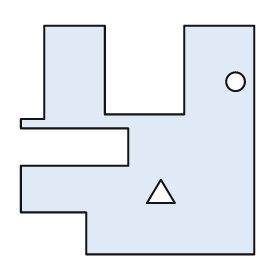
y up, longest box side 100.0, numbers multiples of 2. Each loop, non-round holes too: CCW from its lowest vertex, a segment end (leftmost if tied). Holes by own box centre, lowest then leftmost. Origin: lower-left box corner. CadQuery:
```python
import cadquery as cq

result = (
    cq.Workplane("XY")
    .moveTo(28.0, 0.0)
    .lineTo(100.0, 0.0)
    .lineTo(100.0, 98.0)
    .lineTo(70.0, 98.0)
    .lineTo(70.0, 60.0)
    .lineTo(36.0, 60.0)
    .lineTo(36.0, 98.0)
    .lineTo(10.0, 98.0)
    .lineTo(10.0, 58.0)
    .lineTo(0.0, 58.0)
    .lineTo(0.0, 54.0)
    .lineTo(46.0, 54.0)
    .lineTo(46.0, 38.0)
    .lineTo(0.0, 38.0)
    .lineTo(0.0, 18.0)
    .lineTo(28.0, 18.0)
    .close()
    .moveTo(54.0, 22.0)
    .lineTo(66.0, 22.0)
    .lineTo(60.0, 32.0)
    .close()
    .moveTo(92.0, 74.0)
    .circle(4.0)
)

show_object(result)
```